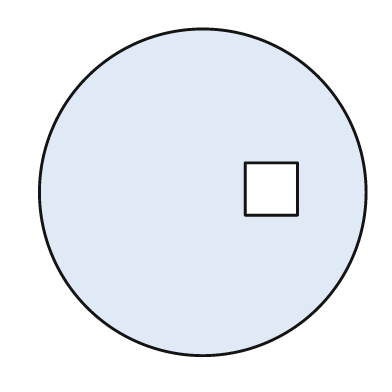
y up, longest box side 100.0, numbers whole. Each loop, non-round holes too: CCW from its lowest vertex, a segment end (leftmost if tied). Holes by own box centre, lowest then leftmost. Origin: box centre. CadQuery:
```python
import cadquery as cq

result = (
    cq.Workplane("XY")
    .moveTo(0.0, 0.0)
    .circle(50.0)
    .moveTo(13.0, -7.0)
    .lineTo(29.0, -7.0)
    .lineTo(29.0, 9.0)
    .lineTo(13.0, 9.0)
    .close()
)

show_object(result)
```